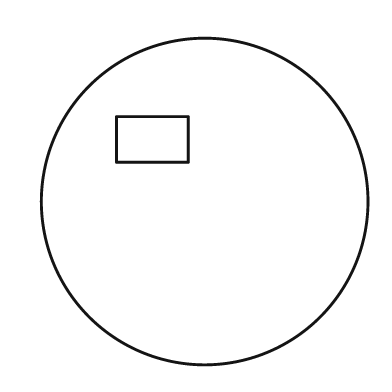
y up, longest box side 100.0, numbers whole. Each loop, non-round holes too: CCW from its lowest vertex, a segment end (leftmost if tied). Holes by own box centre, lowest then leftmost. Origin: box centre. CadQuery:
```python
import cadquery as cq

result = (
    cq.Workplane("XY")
    .moveTo(0.0, 0.0)
    .circle(50.0)
    .moveTo(-27.0, 12.0)
    .lineTo(-5.0, 12.0)
    .lineTo(-5.0, 26.0)
    .lineTo(-27.0, 26.0)
    .close()
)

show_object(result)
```